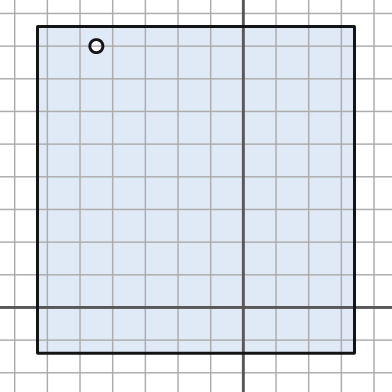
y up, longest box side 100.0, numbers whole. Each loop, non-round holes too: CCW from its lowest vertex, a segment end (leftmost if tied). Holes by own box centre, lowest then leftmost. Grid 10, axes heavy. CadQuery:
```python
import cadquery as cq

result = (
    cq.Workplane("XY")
    .moveTo(-63.0, -14.0)
    .lineTo(34.0, -14.0)
    .lineTo(34.0, 86.0)
    .lineTo(-63.0, 86.0)
    .close()
    .moveTo(-45.0, 80.0)
    .circle(2.0)
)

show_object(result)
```